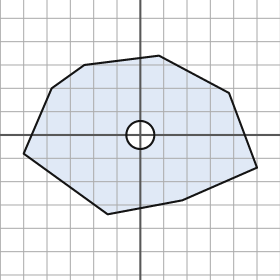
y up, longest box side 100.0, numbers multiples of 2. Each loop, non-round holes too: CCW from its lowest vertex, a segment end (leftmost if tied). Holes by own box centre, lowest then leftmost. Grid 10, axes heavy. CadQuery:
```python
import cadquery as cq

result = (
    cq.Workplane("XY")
    .moveTo(-14.0, -34.0)
    .lineTo(18.0, -28.0)
    .lineTo(50.0, -14.0)
    .lineTo(38.0, 18.0)
    .lineTo(8.0, 34.0)
    .lineTo(-24.0, 30.0)
    .lineTo(-38.0, 20.0)
    .lineTo(-50.0, -8.0)
    .close()
    .moveTo(0.0, 0.0)
    .circle(6.0)
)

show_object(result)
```